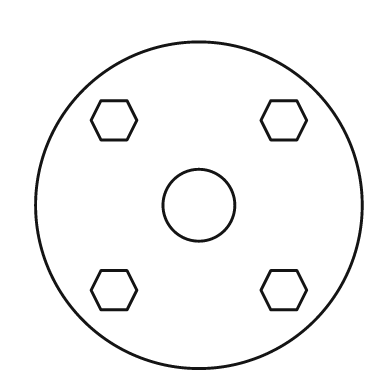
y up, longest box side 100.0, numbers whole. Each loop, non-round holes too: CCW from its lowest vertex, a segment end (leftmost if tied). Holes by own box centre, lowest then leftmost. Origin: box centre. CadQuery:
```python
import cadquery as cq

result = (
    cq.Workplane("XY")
    .moveTo(0.0, 0.0)
    .circle(50.0)
    .moveTo(-30.0, -32.0)
    .lineTo(-22.0, -32.0)
    .lineTo(-19.0, -26.0)
    .lineTo(-22.0, -20.0)
    .lineTo(-30.0, -20.0)
    .lineTo(-33.0, -26.0)
    .close()
    .moveTo(22.0, -32.0)
    .lineTo(30.0, -32.0)
    .lineTo(33.0, -26.0)
    .lineTo(30.0, -20.0)
    .lineTo(22.0, -20.0)
    .lineTo(19.0, -26.0)
    .close()
    .moveTo(0.0, 0.0)
    .circle(11.0)
    .moveTo(-30.0, 20.0)
    .lineTo(-22.0, 20.0)
    .lineTo(-19.0, 26.0)
    .lineTo(-22.0, 32.0)
    .lineTo(-30.0, 32.0)
    .lineTo(-33.0, 26.0)
    .close()
    .moveTo(22.0, 20.0)
    .lineTo(30.0, 20.0)
    .lineTo(33.0, 26.0)
    .lineTo(30.0, 32.0)
    .lineTo(22.0, 32.0)
    .lineTo(19.0, 26.0)
    .close()
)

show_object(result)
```